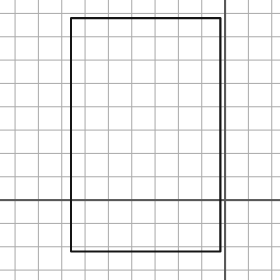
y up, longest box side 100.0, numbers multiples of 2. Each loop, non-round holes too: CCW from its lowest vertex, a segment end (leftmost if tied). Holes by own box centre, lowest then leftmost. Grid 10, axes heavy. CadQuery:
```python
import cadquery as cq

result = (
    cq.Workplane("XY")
    .moveTo(-66.0, -22.0)
    .lineTo(-2.0, -22.0)
    .lineTo(-2.0, 78.0)
    .lineTo(-66.0, 78.0)
    .close()
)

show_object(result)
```